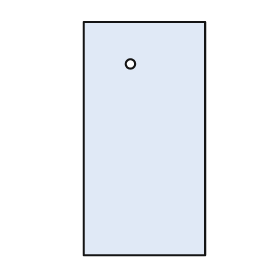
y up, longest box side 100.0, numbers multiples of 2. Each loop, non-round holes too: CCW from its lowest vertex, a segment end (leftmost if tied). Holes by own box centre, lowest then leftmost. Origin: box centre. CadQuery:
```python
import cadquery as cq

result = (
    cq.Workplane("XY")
    .moveTo(-26.0, -50.0)
    .lineTo(26.0, -50.0)
    .lineTo(26.0, 50.0)
    .lineTo(-26.0, 50.0)
    .close()
    .moveTo(-6.0, 32.0)
    .circle(2.0)
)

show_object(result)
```